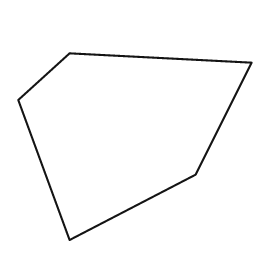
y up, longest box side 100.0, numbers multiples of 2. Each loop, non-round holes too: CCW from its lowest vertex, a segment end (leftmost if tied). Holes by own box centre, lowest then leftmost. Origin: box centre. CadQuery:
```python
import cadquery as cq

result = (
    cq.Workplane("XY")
    .moveTo(-28.0, -40.0)
    .lineTo(26.0, -12.0)
    .lineTo(50.0, 36.0)
    .lineTo(-28.0, 40.0)
    .lineTo(-50.0, 20.0)
    .close()
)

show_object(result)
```